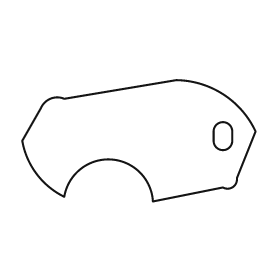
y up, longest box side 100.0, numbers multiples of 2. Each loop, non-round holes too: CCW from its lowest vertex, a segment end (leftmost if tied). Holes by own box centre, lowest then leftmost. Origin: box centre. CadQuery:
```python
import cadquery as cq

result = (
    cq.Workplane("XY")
    .moveTo(6.0, -26.0)
    .lineTo(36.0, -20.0)
    .threePointArc((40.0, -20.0), (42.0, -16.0))
    .lineTo(50.0, 4.0)
    .threePointArc((36.0, 20.0), (16.0, 26.0))
    .lineTo(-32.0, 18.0)
    .threePointArc((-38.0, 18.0), (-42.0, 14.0))
    .lineTo(-50.0, 0.0)
    .threePointArc((-44.0, -14.0), (-32.0, -24.0))
    .threePointArc((-12.0, -8.0), (6.0, -26.0))
    .close()
    .moveTo(32.0, 0.0)
    .threePointArc((36.0, -4.0), (40.0, 0.0))
    .lineTo(40.0, 4.0)
    .threePointArc((36.0, 8.0), (32.0, 4.0))
    .close()
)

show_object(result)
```